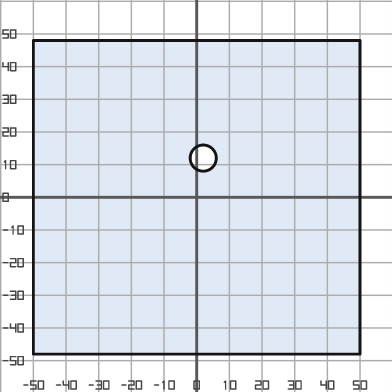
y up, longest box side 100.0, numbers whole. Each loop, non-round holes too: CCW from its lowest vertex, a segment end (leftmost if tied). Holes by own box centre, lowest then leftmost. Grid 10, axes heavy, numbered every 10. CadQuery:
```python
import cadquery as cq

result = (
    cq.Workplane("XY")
    .moveTo(-50.0, -48.0)
    .lineTo(50.0, -48.0)
    .lineTo(50.0, 48.0)
    .lineTo(-50.0, 48.0)
    .close()
    .moveTo(2.0, 12.0)
    .circle(4.0)
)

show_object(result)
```